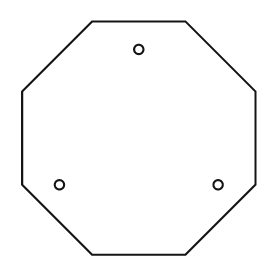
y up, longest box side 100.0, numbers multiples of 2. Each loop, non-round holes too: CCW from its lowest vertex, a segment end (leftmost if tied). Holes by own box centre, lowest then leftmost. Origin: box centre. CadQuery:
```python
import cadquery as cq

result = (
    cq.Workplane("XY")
    .moveTo(-20.0, -50.0)
    .lineTo(20.0, -50.0)
    .lineTo(50.0, -20.0)
    .lineTo(50.0, 20.0)
    .lineTo(20.0, 50.0)
    .lineTo(-20.0, 50.0)
    .lineTo(-50.0, 20.0)
    .lineTo(-50.0, -20.0)
    .close()
    .moveTo(-34.0, -20.0)
    .circle(2.0)
    .moveTo(34.0, -20.0)
    .circle(2.0)
    .moveTo(0.0, 38.0)
    .circle(2.0)
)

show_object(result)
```